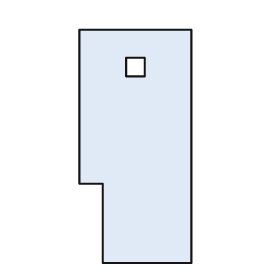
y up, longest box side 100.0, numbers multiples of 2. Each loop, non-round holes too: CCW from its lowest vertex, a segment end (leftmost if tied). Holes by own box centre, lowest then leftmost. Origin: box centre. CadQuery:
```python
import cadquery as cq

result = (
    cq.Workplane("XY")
    .moveTo(-14.0, -50.0)
    .lineTo(24.0, -50.0)
    .lineTo(24.0, 50.0)
    .lineTo(-24.0, 50.0)
    .lineTo(-24.0, -16.0)
    .lineTo(-14.0, -16.0)
    .close()
    .moveTo(-4.0, 30.0)
    .lineTo(4.0, 30.0)
    .lineTo(4.0, 38.0)
    .lineTo(-4.0, 38.0)
    .close()
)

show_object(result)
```